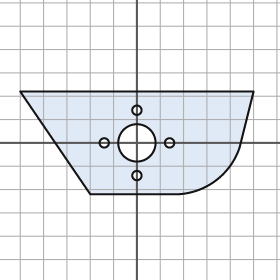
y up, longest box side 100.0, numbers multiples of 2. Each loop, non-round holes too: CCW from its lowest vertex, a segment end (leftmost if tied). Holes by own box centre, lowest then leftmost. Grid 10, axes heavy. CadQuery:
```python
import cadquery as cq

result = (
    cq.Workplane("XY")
    .moveTo(-20.0, -22.0)
    .lineTo(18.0, -22.0)
    .threePointArc((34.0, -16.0), (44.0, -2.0))
    .lineTo(50.0, 22.0)
    .lineTo(-50.0, 22.0)
    .close()
    .moveTo(0.0, -14.0)
    .circle(2.0)
    .moveTo(-14.0, 0.0)
    .circle(2.0)
    .moveTo(0.0, 0.0)
    .circle(8.0)
    .moveTo(14.0, 0.0)
    .circle(2.0)
    .moveTo(0.0, 14.0)
    .circle(2.0)
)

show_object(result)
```